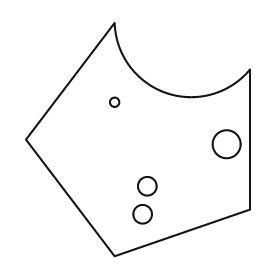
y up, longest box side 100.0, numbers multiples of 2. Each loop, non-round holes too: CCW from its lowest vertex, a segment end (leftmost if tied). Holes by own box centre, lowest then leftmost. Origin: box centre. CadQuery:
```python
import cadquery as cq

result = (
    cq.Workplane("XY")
    .moveTo(-10.0, -50.0)
    .lineTo(48.0, -30.0)
    .lineTo(48.0, 30.0)
    .threePointArc((12.0, 20.0), (-10.0, 50.0))
    .lineTo(-48.0, 0.0)
    .close()
    .moveTo(2.0, -32.0)
    .circle(4.0)
    .moveTo(4.0, -20.0)
    .circle(4.0)
    .moveTo(38.0, -2.0)
    .circle(6.0)
    .moveTo(-10.0, 16.0)
    .circle(2.0)
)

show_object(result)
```